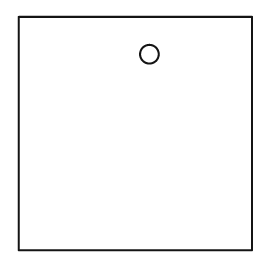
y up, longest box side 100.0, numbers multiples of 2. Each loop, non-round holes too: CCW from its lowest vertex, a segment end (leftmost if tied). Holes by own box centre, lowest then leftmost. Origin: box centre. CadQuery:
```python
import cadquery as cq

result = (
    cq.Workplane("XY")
    .moveTo(-50.0, -50.0)
    .lineTo(50.0, -50.0)
    .lineTo(50.0, 50.0)
    .lineTo(-50.0, 50.0)
    .close()
    .moveTo(6.0, 34.0)
    .circle(4.0)
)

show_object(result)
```